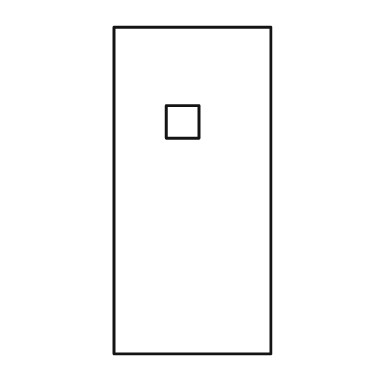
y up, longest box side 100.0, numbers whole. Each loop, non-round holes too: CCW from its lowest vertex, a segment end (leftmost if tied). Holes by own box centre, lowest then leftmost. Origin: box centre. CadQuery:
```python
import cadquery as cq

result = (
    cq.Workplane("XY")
    .moveTo(-24.0, -50.0)
    .lineTo(24.0, -50.0)
    .lineTo(24.0, 50.0)
    .lineTo(-24.0, 50.0)
    .close()
    .moveTo(-8.0, 16.0)
    .lineTo(2.0, 16.0)
    .lineTo(2.0, 26.0)
    .lineTo(-8.0, 26.0)
    .close()
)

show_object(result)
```